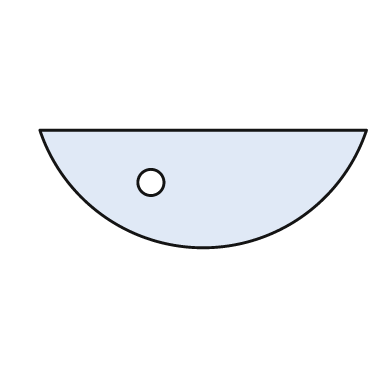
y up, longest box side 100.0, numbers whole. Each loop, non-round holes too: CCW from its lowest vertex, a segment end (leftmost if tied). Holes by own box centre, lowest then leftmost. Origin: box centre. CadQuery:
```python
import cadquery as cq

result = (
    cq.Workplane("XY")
    .moveTo(-50.0, 18.0)
    .threePointArc((0.0, -18.0), (50.0, 18.0))
    .close()
    .moveTo(-16.0, 2.0)
    .circle(4.0)
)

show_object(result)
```